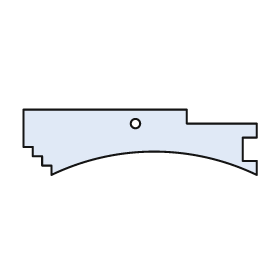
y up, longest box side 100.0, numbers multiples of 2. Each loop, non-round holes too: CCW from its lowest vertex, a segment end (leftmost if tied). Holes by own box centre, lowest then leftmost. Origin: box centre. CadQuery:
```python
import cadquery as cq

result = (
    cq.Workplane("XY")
    .moveTo(-38.0, -14.0)
    .threePointArc((6.0, -4.0), (50.0, -14.0))
    .lineTo(50.0, -8.0)
    .lineTo(44.0, -8.0)
    .lineTo(44.0, 2.0)
    .lineTo(50.0, 2.0)
    .lineTo(50.0, 8.0)
    .lineTo(20.0, 8.0)
    .lineTo(20.0, 14.0)
    .lineTo(-50.0, 14.0)
    .lineTo(-50.0, -2.0)
    .lineTo(-46.0, -2.0)
    .lineTo(-46.0, -6.0)
    .lineTo(-42.0, -6.0)
    .lineTo(-42.0, -10.0)
    .lineTo(-38.0, -10.0)
    .close()
    .moveTo(-2.0, 8.0)
    .circle(2.0)
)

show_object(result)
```